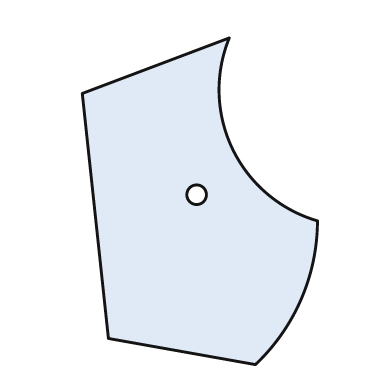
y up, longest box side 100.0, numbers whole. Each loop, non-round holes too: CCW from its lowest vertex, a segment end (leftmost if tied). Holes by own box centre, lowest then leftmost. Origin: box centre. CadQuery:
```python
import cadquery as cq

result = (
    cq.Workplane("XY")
    .moveTo(17.0, -50.0)
    .threePointArc((31.0, -30.0), (36.0, -6.0))
    .threePointArc((10.0, 16.0), (9.0, 50.0))
    .lineTo(-36.0, 33.0)
    .lineTo(-28.0, -42.0)
    .close()
    .moveTo(-1.0, 2.0)
    .circle(3.0)
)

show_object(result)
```